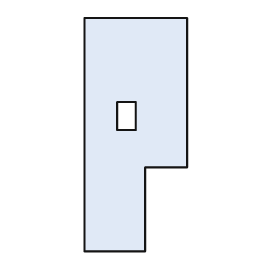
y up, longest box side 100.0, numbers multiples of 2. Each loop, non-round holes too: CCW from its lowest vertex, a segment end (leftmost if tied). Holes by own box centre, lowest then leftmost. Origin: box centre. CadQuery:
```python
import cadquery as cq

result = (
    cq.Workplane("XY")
    .moveTo(-22.0, -50.0)
    .lineTo(4.0, -50.0)
    .lineTo(4.0, -14.0)
    .lineTo(22.0, -14.0)
    .lineTo(22.0, 50.0)
    .lineTo(-22.0, 50.0)
    .close()
    .moveTo(-8.0, 2.0)
    .lineTo(0.0, 2.0)
    .lineTo(0.0, 14.0)
    .lineTo(-8.0, 14.0)
    .close()
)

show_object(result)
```